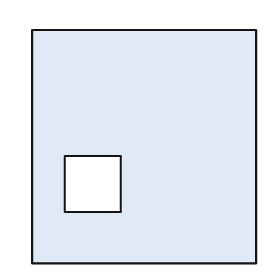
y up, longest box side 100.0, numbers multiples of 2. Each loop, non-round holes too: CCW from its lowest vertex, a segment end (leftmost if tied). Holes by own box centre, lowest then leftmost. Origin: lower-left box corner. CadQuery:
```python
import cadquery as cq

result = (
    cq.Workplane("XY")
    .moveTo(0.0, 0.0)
    .lineTo(96.0, 0.0)
    .lineTo(96.0, 100.0)
    .lineTo(0.0, 100.0)
    .close()
    .moveTo(14.0, 22.0)
    .lineTo(38.0, 22.0)
    .lineTo(38.0, 46.0)
    .lineTo(14.0, 46.0)
    .close()
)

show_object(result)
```